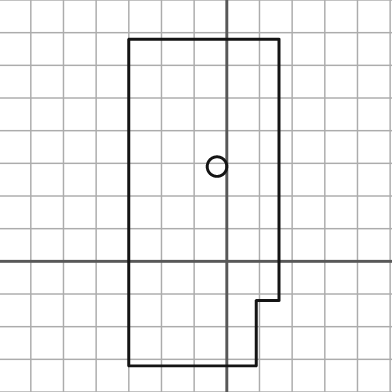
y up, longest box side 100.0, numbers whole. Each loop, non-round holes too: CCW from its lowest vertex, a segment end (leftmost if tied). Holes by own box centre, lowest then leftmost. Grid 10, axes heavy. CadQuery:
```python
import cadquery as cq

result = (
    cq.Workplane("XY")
    .moveTo(-30.0, -32.0)
    .lineTo(9.0, -32.0)
    .lineTo(9.0, -12.0)
    .lineTo(16.0, -12.0)
    .lineTo(16.0, 68.0)
    .lineTo(-30.0, 68.0)
    .close()
    .moveTo(-3.0, 29.0)
    .circle(3.0)
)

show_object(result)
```